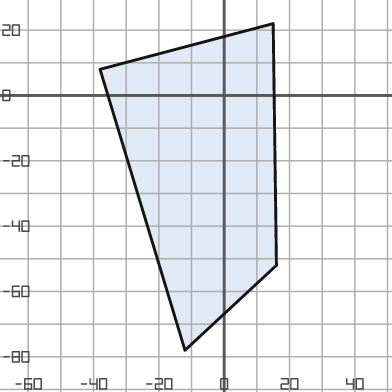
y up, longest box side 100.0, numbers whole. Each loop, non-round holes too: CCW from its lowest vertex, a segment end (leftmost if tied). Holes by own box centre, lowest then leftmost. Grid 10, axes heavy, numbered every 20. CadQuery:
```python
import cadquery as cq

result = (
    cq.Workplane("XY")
    .moveTo(-12.0, -78.0)
    .lineTo(16.0, -52.0)
    .lineTo(15.0, 22.0)
    .lineTo(-38.0, 8.0)
    .close()
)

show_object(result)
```